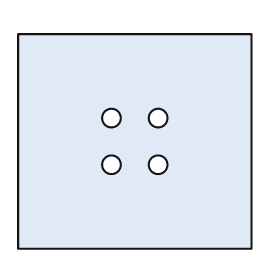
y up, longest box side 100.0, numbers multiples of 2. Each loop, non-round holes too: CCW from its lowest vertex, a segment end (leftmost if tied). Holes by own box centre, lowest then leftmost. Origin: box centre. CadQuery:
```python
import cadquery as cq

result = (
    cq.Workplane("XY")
    .moveTo(-50.0, -46.0)
    .lineTo(50.0, -46.0)
    .lineTo(50.0, 46.0)
    .lineTo(-50.0, 46.0)
    .close()
    .moveTo(-10.0, -10.0)
    .circle(4.0)
    .moveTo(10.0, -10.0)
    .circle(4.0)
    .moveTo(-10.0, 10.0)
    .circle(4.0)
    .moveTo(10.0, 10.0)
    .circle(4.0)
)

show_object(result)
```